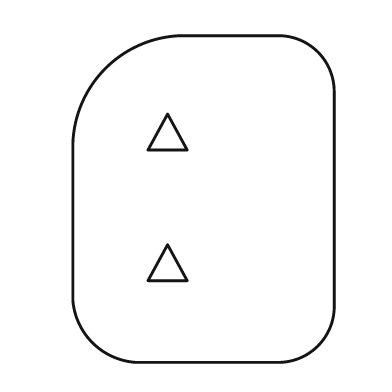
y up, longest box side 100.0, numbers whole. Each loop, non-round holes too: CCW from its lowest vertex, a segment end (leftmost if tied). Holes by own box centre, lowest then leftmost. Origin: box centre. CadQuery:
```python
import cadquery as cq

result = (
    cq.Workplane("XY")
    .moveTo(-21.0, -50.0)
    .lineTo(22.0, -50.0)
    .threePointArc((35.0, -45.0), (40.0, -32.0))
    .lineTo(40.0, 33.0)
    .threePointArc((35.0, 45.0), (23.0, 50.0))
    .lineTo(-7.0, 50.0)
    .threePointArc((-30.0, 40.0), (-40.0, 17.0))
    .lineTo(-40.0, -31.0)
    .threePointArc((-34.0, -44.0), (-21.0, -50.0))
    .close()
    .moveTo(-17.0, -25.0)
    .lineTo(-5.0, -25.0)
    .lineTo(-11.0, -14.0)
    .close()
    .moveTo(-17.0, 15.0)
    .lineTo(-5.0, 15.0)
    .lineTo(-11.0, 26.0)
    .close()
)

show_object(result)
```